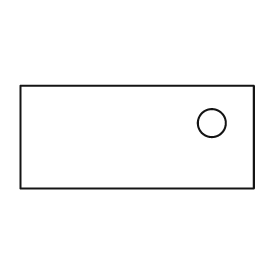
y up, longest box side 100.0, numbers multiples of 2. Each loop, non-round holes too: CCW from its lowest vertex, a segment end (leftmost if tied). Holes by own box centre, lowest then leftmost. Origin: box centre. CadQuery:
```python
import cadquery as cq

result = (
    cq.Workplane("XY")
    .moveTo(-50.0, -22.0)
    .lineTo(50.0, -22.0)
    .lineTo(50.0, 22.0)
    .lineTo(-50.0, 22.0)
    .close()
    .moveTo(32.0, 6.0)
    .circle(6.0)
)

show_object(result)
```